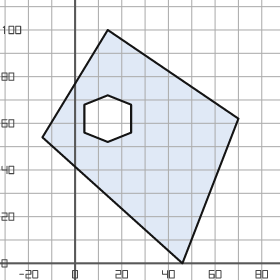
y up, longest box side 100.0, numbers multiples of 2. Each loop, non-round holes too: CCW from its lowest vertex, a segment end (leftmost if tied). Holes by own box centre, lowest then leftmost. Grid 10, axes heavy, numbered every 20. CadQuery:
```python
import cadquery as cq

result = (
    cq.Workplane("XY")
    .moveTo(46.0, 0.0)
    .lineTo(70.0, 62.0)
    .lineTo(14.0, 100.0)
    .lineTo(-14.0, 54.0)
    .close()
    .moveTo(14.0, 52.0)
    .lineTo(24.0, 56.0)
    .lineTo(24.0, 68.0)
    .lineTo(14.0, 72.0)
    .lineTo(4.0, 68.0)
    .lineTo(4.0, 56.0)
    .close()
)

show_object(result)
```